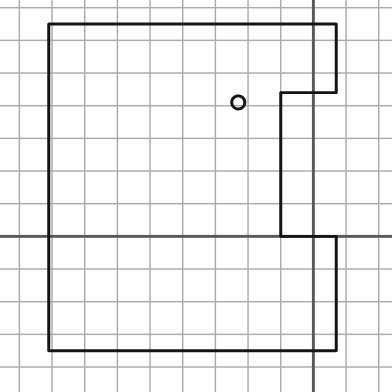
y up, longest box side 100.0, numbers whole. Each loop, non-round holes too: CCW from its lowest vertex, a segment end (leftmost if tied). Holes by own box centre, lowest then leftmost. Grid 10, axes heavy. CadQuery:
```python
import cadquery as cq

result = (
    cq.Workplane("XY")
    .moveTo(-81.0, -35.0)
    .lineTo(7.0, -35.0)
    .lineTo(7.0, 0.0)
    .lineTo(-10.0, 0.0)
    .lineTo(-10.0, 44.0)
    .lineTo(7.0, 44.0)
    .lineTo(7.0, 65.0)
    .lineTo(-81.0, 65.0)
    .close()
    .moveTo(-23.0, 41.0)
    .circle(2.0)
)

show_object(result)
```